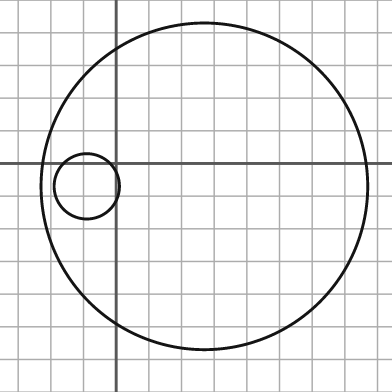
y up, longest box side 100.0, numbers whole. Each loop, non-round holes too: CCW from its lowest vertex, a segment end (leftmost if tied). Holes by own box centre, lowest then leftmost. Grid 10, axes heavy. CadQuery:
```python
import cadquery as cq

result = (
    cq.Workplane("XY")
    .moveTo(27.0, -7.0)
    .circle(50.0)
    .moveTo(-9.0, -7.0)
    .circle(10.0)
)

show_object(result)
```